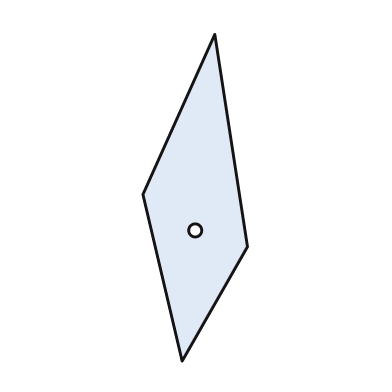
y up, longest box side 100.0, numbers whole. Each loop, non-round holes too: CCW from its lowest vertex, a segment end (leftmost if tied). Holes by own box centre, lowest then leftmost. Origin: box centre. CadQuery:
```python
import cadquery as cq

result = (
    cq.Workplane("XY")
    .moveTo(-4.0, -50.0)
    .lineTo(16.0, -15.0)
    .lineTo(6.0, 50.0)
    .lineTo(-16.0, 1.0)
    .close()
    .moveTo(0.0, -10.0)
    .circle(2.0)
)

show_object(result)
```